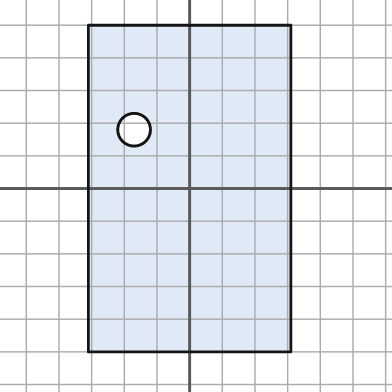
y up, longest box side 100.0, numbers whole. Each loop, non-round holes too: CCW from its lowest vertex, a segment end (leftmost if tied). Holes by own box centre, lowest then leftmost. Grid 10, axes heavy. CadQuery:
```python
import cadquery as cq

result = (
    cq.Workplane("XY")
    .moveTo(-31.0, -50.0)
    .lineTo(31.0, -50.0)
    .lineTo(31.0, 50.0)
    .lineTo(-31.0, 50.0)
    .close()
    .moveTo(-17.0, 18.0)
    .circle(5.0)
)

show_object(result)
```